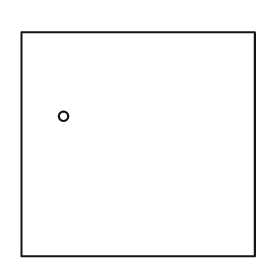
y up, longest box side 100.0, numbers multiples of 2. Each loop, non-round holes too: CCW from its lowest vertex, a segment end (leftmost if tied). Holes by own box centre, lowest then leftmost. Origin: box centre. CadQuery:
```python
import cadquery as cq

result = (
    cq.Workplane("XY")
    .moveTo(-50.0, -48.0)
    .lineTo(50.0, -48.0)
    .lineTo(50.0, 48.0)
    .lineTo(-50.0, 48.0)
    .close()
    .moveTo(-32.0, 12.0)
    .circle(2.0)
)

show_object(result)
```